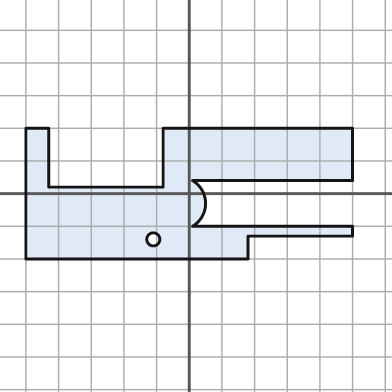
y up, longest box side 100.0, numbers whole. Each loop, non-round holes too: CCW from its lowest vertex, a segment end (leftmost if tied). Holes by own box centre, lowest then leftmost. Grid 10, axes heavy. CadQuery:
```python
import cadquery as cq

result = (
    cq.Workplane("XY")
    .moveTo(-50.0, -20.0)
    .lineTo(18.0, -20.0)
    .lineTo(18.0, -13.0)
    .lineTo(50.0, -13.0)
    .lineTo(50.0, -10.0)
    .lineTo(1.0, -10.0)
    .threePointArc((5.0, -3.0), (1.0, 4.0))
    .lineTo(50.0, 4.0)
    .lineTo(50.0, 20.0)
    .lineTo(-8.0, 20.0)
    .lineTo(-8.0, 2.0)
    .lineTo(-43.0, 2.0)
    .lineTo(-43.0, 20.0)
    .lineTo(-50.0, 20.0)
    .close()
    .moveTo(-11.0, -14.0)
    .circle(2.0)
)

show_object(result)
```